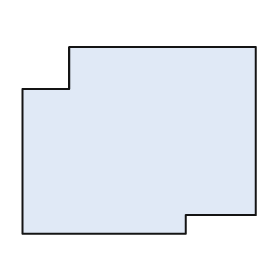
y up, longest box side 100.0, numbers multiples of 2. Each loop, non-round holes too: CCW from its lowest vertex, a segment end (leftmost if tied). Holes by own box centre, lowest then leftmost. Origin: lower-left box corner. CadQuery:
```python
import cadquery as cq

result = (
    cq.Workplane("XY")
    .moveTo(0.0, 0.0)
    .lineTo(70.0, 0.0)
    .lineTo(70.0, 8.0)
    .lineTo(100.0, 8.0)
    .lineTo(100.0, 80.0)
    .lineTo(20.0, 80.0)
    .lineTo(20.0, 62.0)
    .lineTo(0.0, 62.0)
    .close()
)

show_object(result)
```